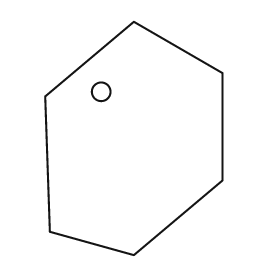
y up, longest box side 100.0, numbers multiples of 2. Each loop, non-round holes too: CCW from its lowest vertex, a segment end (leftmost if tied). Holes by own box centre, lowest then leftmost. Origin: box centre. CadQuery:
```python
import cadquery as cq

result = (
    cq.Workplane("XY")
    .moveTo(0.0, -50.0)
    .lineTo(38.0, -18.0)
    .lineTo(38.0, 28.0)
    .lineTo(0.0, 50.0)
    .lineTo(-38.0, 18.0)
    .lineTo(-36.0, -40.0)
    .close()
    .moveTo(-14.0, 20.0)
    .circle(4.0)
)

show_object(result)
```